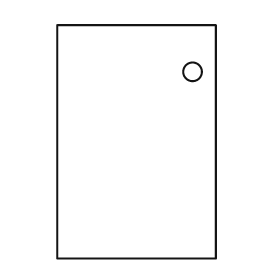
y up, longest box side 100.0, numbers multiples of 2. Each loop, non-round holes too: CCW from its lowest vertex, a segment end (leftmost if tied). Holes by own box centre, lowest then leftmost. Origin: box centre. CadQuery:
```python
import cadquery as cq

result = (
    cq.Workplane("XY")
    .moveTo(-34.0, -50.0)
    .lineTo(34.0, -50.0)
    .lineTo(34.0, 50.0)
    .lineTo(-34.0, 50.0)
    .close()
    .moveTo(24.0, 30.0)
    .circle(4.0)
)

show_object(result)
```